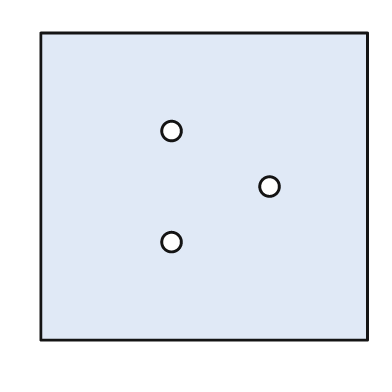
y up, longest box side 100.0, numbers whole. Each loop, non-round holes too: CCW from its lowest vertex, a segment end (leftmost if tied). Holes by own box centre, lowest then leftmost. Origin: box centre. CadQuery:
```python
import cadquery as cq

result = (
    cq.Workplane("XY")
    .moveTo(-50.0, -47.0)
    .lineTo(50.0, -47.0)
    .lineTo(50.0, 47.0)
    .lineTo(-50.0, 47.0)
    .close()
    .moveTo(-10.0, -17.0)
    .circle(3.0)
    .moveTo(20.0, 0.0)
    .circle(3.0)
    .moveTo(-10.0, 17.0)
    .circle(3.0)
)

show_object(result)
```